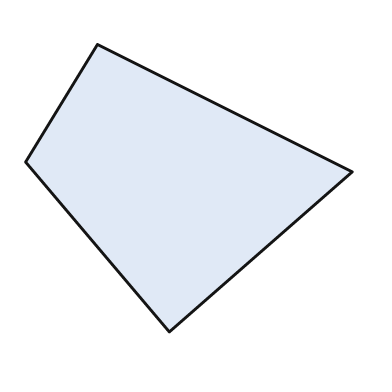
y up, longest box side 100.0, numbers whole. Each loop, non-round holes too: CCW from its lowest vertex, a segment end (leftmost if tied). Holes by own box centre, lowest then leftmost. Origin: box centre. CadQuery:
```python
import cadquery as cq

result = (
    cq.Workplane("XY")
    .moveTo(-6.0, -44.0)
    .lineTo(50.0, 5.0)
    .lineTo(-28.0, 44.0)
    .lineTo(-50.0, 8.0)
    .close()
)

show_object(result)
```